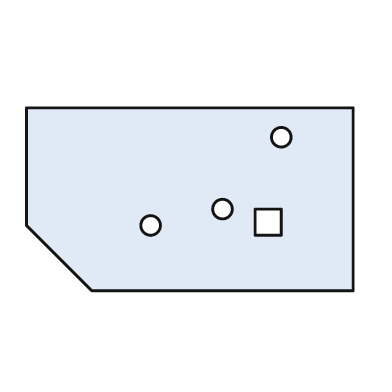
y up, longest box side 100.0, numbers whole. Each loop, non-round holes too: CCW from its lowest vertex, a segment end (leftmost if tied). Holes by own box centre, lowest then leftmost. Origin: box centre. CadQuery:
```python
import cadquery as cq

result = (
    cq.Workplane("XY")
    .moveTo(-30.0, -28.0)
    .lineTo(50.0, -28.0)
    .lineTo(50.0, 28.0)
    .lineTo(-50.0, 28.0)
    .lineTo(-50.0, -8.0)
    .close()
    .moveTo(-12.0, -8.0)
    .circle(3.0)
    .moveTo(20.0, -11.0)
    .lineTo(28.0, -11.0)
    .lineTo(28.0, -3.0)
    .lineTo(20.0, -3.0)
    .close()
    .moveTo(10.0, -3.0)
    .circle(3.0)
    .moveTo(28.0, 19.0)
    .circle(3.0)
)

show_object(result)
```